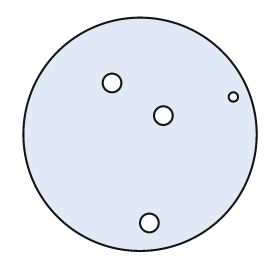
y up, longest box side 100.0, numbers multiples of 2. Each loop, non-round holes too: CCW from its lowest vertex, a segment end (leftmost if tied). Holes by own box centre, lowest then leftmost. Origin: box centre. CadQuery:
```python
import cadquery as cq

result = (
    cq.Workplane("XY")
    .moveTo(0.0, 0.0)
    .circle(50.0)
    .moveTo(4.0, -38.0)
    .circle(4.0)
    .moveTo(10.0, 8.0)
    .circle(4.0)
    .moveTo(40.0, 16.0)
    .circle(2.0)
    .moveTo(-12.0, 22.0)
    .circle(4.0)
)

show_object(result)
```